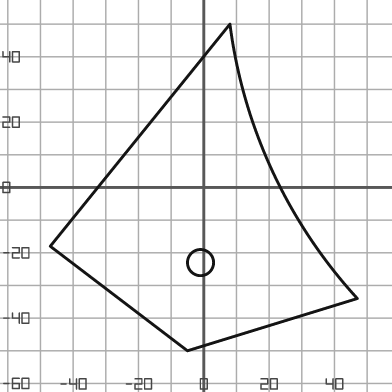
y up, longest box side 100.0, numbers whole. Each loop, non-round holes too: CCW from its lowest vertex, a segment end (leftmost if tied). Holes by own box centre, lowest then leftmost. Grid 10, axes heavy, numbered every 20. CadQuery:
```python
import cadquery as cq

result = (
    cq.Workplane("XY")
    .moveTo(-5.0, -50.0)
    .lineTo(47.0, -34.0)
    .threePointArc((21.0, 5.0), (8.0, 50.0))
    .lineTo(-47.0, -18.0)
    .close()
    .moveTo(-1.0, -23.0)
    .circle(4.0)
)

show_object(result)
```